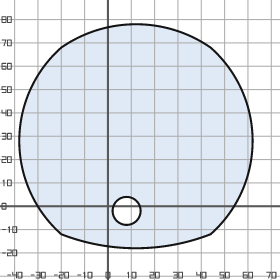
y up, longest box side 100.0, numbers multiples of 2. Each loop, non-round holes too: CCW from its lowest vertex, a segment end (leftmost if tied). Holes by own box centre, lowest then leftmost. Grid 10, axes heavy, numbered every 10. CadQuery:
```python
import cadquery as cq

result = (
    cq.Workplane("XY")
    .moveTo(-20.0, -12.0)
    .threePointArc((12.0, -18.0), (44.0, -12.0))
    .threePointArc((62.0, 28.0), (44.0, 68.0))
    .threePointArc((12.0, 78.0), (-20.0, 68.0))
    .threePointArc((-38.0, 28.0), (-20.0, -12.0))
    .close()
    .moveTo(8.0, -2.0)
    .circle(6.0)
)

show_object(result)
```